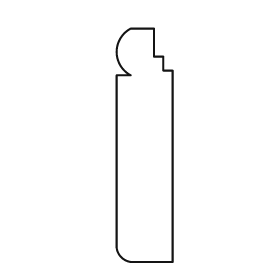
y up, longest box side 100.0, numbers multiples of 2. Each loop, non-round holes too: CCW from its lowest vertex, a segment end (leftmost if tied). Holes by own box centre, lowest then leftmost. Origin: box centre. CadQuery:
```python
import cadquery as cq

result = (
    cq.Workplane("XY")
    .moveTo(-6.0, -50.0)
    .lineTo(12.0, -50.0)
    .lineTo(12.0, 32.0)
    .lineTo(8.0, 32.0)
    .lineTo(8.0, 38.0)
    .lineTo(4.0, 38.0)
    .lineTo(4.0, 50.0)
    .lineTo(-6.0, 50.0)
    .threePointArc((-12.0, 40.0), (-6.0, 30.0))
    .lineTo(-12.0, 30.0)
    .lineTo(-12.0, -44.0)
    .threePointArc((-10.0, -48.0), (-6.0, -50.0))
    .close()
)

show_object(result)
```